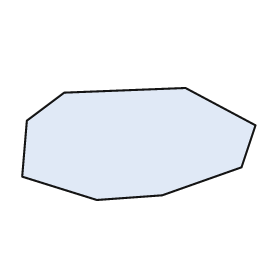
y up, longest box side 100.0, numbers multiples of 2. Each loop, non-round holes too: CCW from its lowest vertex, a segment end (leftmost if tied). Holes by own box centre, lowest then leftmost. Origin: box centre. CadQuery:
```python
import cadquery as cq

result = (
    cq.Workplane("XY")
    .moveTo(-18.0, -24.0)
    .lineTo(10.0, -22.0)
    .lineTo(44.0, -10.0)
    .lineTo(50.0, 8.0)
    .lineTo(20.0, 24.0)
    .lineTo(-32.0, 22.0)
    .lineTo(-48.0, 10.0)
    .lineTo(-50.0, -14.0)
    .close()
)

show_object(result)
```